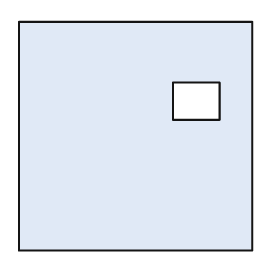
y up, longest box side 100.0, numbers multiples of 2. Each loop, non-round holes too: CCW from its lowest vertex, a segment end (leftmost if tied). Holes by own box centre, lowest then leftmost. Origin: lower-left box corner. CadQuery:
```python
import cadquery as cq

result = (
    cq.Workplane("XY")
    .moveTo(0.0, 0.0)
    .lineTo(100.0, 0.0)
    .lineTo(100.0, 98.0)
    .lineTo(0.0, 98.0)
    .close()
    .moveTo(66.0, 56.0)
    .lineTo(86.0, 56.0)
    .lineTo(86.0, 72.0)
    .lineTo(66.0, 72.0)
    .close()
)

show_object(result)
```